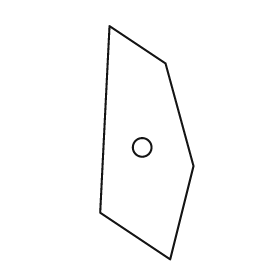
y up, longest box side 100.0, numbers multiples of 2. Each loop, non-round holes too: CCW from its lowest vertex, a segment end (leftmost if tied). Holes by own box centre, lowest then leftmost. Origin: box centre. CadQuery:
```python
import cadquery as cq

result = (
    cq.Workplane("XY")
    .moveTo(10.0, -50.0)
    .lineTo(20.0, -10.0)
    .lineTo(8.0, 34.0)
    .lineTo(-16.0, 50.0)
    .lineTo(-20.0, -30.0)
    .close()
    .moveTo(-2.0, -2.0)
    .circle(4.0)
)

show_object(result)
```